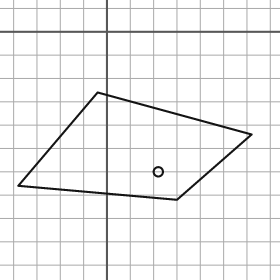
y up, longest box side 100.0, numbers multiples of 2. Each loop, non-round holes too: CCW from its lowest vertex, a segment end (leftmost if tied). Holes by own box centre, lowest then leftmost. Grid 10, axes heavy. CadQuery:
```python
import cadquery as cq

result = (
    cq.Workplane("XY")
    .moveTo(30.0, -72.0)
    .lineTo(62.0, -44.0)
    .lineTo(-4.0, -26.0)
    .lineTo(-38.0, -66.0)
    .close()
    .moveTo(22.0, -60.0)
    .circle(2.0)
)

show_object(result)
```